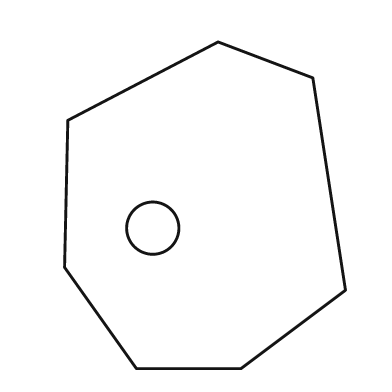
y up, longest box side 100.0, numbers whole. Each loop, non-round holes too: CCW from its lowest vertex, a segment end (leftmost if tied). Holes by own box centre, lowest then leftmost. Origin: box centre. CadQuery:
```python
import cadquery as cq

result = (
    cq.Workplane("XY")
    .moveTo(-21.0, -50.0)
    .lineTo(11.0, -50.0)
    .lineTo(43.0, -26.0)
    .lineTo(33.0, 39.0)
    .lineTo(4.0, 50.0)
    .lineTo(-42.0, 26.0)
    .lineTo(-43.0, -19.0)
    .close()
    .moveTo(-16.0, -7.0)
    .circle(8.0)
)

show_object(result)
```